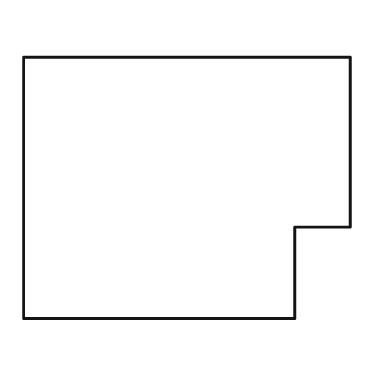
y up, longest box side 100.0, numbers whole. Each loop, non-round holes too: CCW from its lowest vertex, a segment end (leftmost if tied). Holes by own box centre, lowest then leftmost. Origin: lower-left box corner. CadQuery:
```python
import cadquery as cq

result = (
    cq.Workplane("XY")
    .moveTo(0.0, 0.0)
    .lineTo(83.0, 0.0)
    .lineTo(83.0, 28.0)
    .lineTo(100.0, 28.0)
    .lineTo(100.0, 80.0)
    .lineTo(0.0, 80.0)
    .close()
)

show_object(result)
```